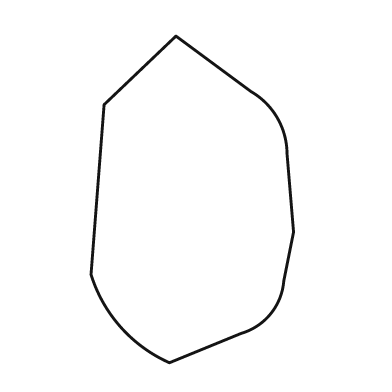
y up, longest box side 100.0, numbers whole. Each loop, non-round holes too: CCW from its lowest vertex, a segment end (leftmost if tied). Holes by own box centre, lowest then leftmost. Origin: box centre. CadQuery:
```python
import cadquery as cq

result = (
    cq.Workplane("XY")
    .moveTo(-7.0, -50.0)
    .lineTo(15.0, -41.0)
    .threePointArc((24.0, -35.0), (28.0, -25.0))
    .lineTo(31.0, -10.0)
    .lineTo(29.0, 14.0)
    .threePointArc((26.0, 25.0), (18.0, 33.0))
    .lineTo(-5.0, 50.0)
    .lineTo(-27.0, 29.0)
    .lineTo(-31.0, -23.0)
    .threePointArc((-22.0, -39.0), (-7.0, -50.0))
    .close()
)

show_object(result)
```